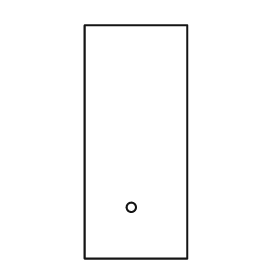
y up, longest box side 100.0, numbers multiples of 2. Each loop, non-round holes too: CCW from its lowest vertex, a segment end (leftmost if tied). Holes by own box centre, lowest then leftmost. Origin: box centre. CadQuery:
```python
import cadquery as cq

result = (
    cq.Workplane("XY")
    .moveTo(-22.0, -50.0)
    .lineTo(22.0, -50.0)
    .lineTo(22.0, 50.0)
    .lineTo(-22.0, 50.0)
    .close()
    .moveTo(-2.0, -28.0)
    .circle(2.0)
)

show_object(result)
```